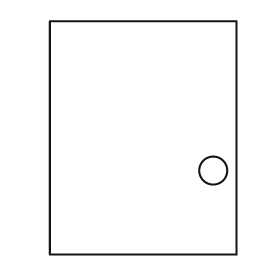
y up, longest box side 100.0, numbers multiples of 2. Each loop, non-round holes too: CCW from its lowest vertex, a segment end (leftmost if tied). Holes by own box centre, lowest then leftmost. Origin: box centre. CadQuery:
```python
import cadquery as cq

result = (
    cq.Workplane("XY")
    .moveTo(-40.0, -50.0)
    .lineTo(40.0, -50.0)
    .lineTo(40.0, 50.0)
    .lineTo(-40.0, 50.0)
    .close()
    .moveTo(30.0, -14.0)
    .circle(6.0)
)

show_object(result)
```